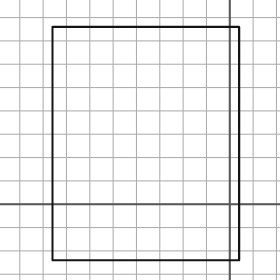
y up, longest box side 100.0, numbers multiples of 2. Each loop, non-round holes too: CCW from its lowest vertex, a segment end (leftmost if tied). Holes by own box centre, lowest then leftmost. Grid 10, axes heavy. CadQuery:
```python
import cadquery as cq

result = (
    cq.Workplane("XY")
    .moveTo(-76.0, -24.0)
    .lineTo(4.0, -24.0)
    .lineTo(4.0, 76.0)
    .lineTo(-76.0, 76.0)
    .close()
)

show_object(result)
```